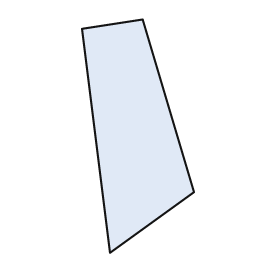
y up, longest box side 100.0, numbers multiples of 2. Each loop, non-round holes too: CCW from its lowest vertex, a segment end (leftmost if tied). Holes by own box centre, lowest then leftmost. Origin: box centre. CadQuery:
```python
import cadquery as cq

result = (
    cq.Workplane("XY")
    .moveTo(-12.0, -50.0)
    .lineTo(24.0, -24.0)
    .lineTo(2.0, 50.0)
    .lineTo(-24.0, 46.0)
    .close()
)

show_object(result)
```